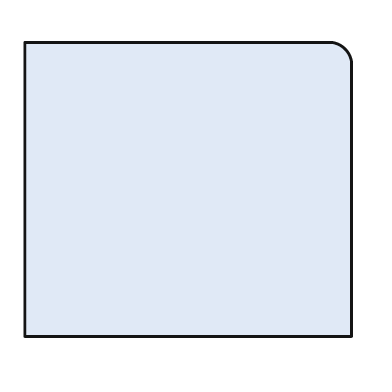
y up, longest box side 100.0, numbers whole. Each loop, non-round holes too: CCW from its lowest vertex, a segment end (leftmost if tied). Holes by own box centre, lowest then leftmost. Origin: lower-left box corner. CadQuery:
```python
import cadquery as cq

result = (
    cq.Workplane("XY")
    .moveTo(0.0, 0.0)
    .lineTo(100.0, 0.0)
    .lineTo(100.0, 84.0)
    .threePointArc((98.0, 88.0), (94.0, 90.0))
    .lineTo(0.0, 90.0)
    .close()
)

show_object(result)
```